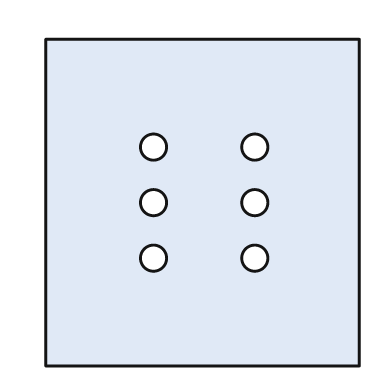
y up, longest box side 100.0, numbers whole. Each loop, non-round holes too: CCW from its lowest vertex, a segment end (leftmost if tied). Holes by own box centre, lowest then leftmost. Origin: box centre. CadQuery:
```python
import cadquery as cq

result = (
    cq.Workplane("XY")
    .moveTo(-48.0, -50.0)
    .lineTo(48.0, -50.0)
    .lineTo(48.0, 50.0)
    .lineTo(-48.0, 50.0)
    .close()
    .moveTo(-15.0, -17.0)
    .circle(4.0)
    .moveTo(16.0, -17.0)
    .circle(4.0)
    .moveTo(-15.0, 0.0)
    .circle(4.0)
    .moveTo(16.0, 0.0)
    .circle(4.0)
    .moveTo(-15.0, 17.0)
    .circle(4.0)
    .moveTo(16.0, 17.0)
    .circle(4.0)
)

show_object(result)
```